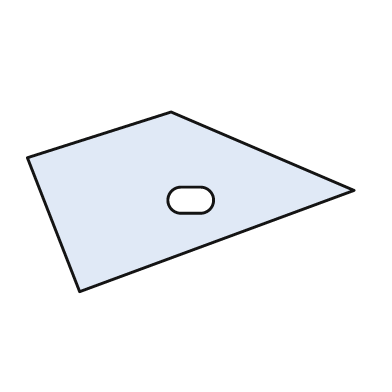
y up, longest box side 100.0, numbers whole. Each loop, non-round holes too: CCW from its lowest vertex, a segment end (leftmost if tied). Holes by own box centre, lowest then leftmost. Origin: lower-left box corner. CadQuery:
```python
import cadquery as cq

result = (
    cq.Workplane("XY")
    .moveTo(16.0, 0.0)
    .lineTo(100.0, 31.0)
    .lineTo(44.0, 55.0)
    .lineTo(0.0, 41.0)
    .close()
    .moveTo(47.0, 24.0)
    .lineTo(53.0, 24.0)
    .threePointArc((57.0, 28.0), (53.0, 32.0))
    .lineTo(47.0, 32.0)
    .threePointArc((43.0, 28.0), (47.0, 24.0))
    .close()
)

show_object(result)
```